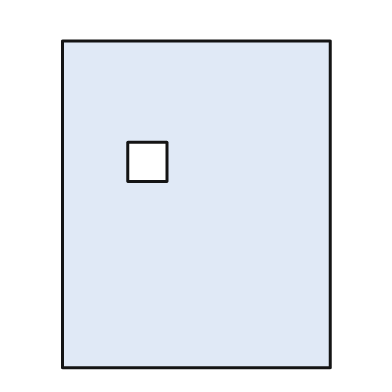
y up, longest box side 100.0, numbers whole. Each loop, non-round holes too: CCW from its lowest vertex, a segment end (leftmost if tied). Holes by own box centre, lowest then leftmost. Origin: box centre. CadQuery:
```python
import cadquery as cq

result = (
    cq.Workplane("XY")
    .moveTo(-41.0, -50.0)
    .lineTo(41.0, -50.0)
    .lineTo(41.0, 50.0)
    .lineTo(-41.0, 50.0)
    .close()
    .moveTo(-21.0, 7.0)
    .lineTo(-9.0, 7.0)
    .lineTo(-9.0, 19.0)
    .lineTo(-21.0, 19.0)
    .close()
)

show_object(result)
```